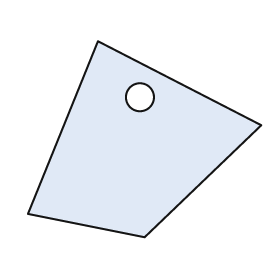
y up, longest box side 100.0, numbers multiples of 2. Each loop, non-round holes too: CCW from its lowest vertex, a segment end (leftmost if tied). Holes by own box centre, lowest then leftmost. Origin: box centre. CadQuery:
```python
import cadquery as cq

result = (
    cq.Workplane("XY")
    .moveTo(0.0, -42.0)
    .lineTo(50.0, 6.0)
    .lineTo(-20.0, 42.0)
    .lineTo(-50.0, -32.0)
    .close()
    .moveTo(-2.0, 18.0)
    .circle(6.0)
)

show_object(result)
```